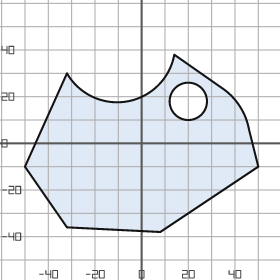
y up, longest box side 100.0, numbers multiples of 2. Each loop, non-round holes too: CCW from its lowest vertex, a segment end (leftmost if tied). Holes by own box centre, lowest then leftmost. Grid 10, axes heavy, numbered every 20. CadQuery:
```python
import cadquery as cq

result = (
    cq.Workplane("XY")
    .moveTo(8.0, -38.0)
    .lineTo(50.0, -10.0)
    .lineTo(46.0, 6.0)
    .threePointArc((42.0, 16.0), (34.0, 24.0))
    .lineTo(14.0, 38.0)
    .threePointArc((-6.0, 18.0), (-32.0, 30.0))
    .lineTo(-50.0, -10.0)
    .lineTo(-32.0, -36.0)
    .close()
    .moveTo(20.0, 18.0)
    .circle(8.0)
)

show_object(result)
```